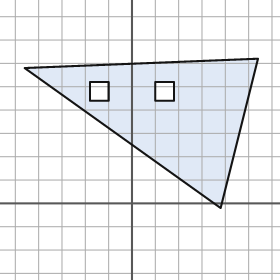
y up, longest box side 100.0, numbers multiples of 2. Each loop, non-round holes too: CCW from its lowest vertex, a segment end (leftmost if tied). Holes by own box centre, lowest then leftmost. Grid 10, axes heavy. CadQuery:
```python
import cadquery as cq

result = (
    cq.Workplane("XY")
    .moveTo(38.0, -2.0)
    .lineTo(54.0, 62.0)
    .lineTo(-46.0, 58.0)
    .close()
    .moveTo(-18.0, 44.0)
    .lineTo(-10.0, 44.0)
    .lineTo(-10.0, 52.0)
    .lineTo(-18.0, 52.0)
    .close()
    .moveTo(10.0, 44.0)
    .lineTo(18.0, 44.0)
    .lineTo(18.0, 52.0)
    .lineTo(10.0, 52.0)
    .close()
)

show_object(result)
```